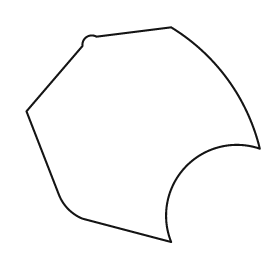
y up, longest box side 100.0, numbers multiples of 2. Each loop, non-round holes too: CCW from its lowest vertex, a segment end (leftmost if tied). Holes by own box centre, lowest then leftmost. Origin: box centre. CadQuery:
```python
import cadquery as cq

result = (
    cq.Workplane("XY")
    .moveTo(12.0, -46.0)
    .threePointArc((18.0, -14.0), (50.0, -6.0))
    .threePointArc((36.0, 24.0), (12.0, 46.0))
    .lineTo(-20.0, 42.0)
    .threePointArc((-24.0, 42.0), (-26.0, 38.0))
    .lineTo(-50.0, 10.0)
    .lineTo(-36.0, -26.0)
    .threePointArc((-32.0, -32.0), (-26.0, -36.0))
    .close()
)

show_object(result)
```